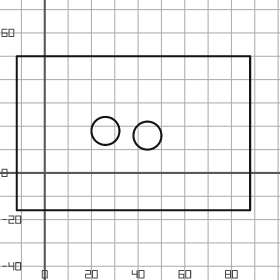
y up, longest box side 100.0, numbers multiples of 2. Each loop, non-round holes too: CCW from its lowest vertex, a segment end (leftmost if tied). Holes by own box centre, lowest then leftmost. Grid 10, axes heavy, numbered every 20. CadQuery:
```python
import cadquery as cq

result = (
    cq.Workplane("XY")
    .moveTo(-12.0, -16.0)
    .lineTo(88.0, -16.0)
    .lineTo(88.0, 50.0)
    .lineTo(-12.0, 50.0)
    .close()
    .moveTo(44.0, 16.0)
    .circle(6.0)
    .moveTo(26.0, 18.0)
    .circle(6.0)
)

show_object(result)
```